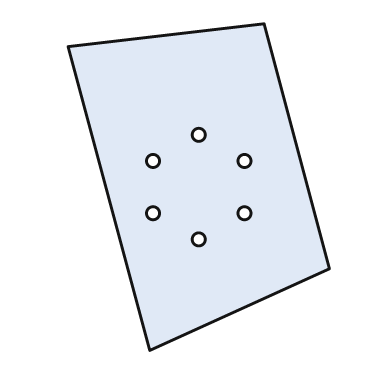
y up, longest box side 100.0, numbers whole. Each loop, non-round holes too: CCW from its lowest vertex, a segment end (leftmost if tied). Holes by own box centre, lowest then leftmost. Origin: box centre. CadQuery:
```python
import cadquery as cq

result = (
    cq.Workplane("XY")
    .moveTo(-15.0, -50.0)
    .lineTo(40.0, -25.0)
    .lineTo(20.0, 50.0)
    .lineTo(-40.0, 43.0)
    .close()
    .moveTo(0.0, -16.0)
    .circle(2.0)
    .moveTo(-14.0, -8.0)
    .circle(2.0)
    .moveTo(14.0, -8.0)
    .circle(2.0)
    .moveTo(-14.0, 8.0)
    .circle(2.0)
    .moveTo(14.0, 8.0)
    .circle(2.0)
    .moveTo(0.0, 16.0)
    .circle(2.0)
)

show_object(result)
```